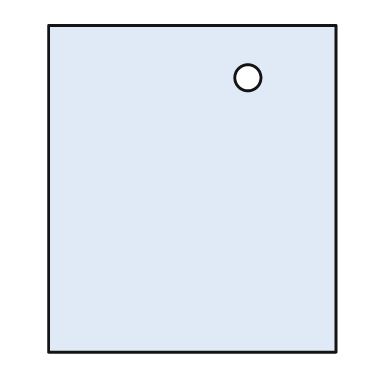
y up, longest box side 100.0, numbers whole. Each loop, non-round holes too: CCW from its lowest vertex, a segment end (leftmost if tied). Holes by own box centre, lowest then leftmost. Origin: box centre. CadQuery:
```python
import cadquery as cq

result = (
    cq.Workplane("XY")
    .moveTo(-44.0, -50.0)
    .lineTo(44.0, -50.0)
    .lineTo(44.0, 50.0)
    .lineTo(-44.0, 50.0)
    .close()
    .moveTo(17.0, 34.0)
    .circle(4.0)
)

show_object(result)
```